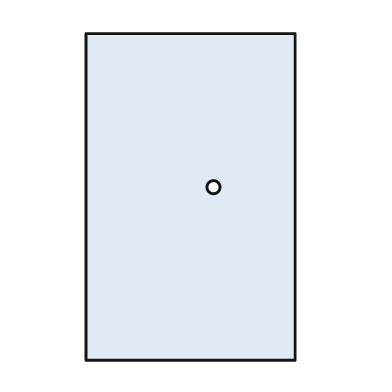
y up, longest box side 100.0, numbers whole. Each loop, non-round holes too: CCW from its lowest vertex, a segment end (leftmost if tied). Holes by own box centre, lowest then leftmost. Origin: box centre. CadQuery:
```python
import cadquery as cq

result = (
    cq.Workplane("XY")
    .moveTo(-32.0, -50.0)
    .lineTo(32.0, -50.0)
    .lineTo(32.0, 50.0)
    .lineTo(-32.0, 50.0)
    .close()
    .moveTo(7.0, 3.0)
    .circle(2.0)
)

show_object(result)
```